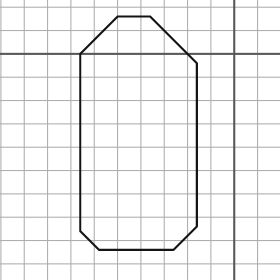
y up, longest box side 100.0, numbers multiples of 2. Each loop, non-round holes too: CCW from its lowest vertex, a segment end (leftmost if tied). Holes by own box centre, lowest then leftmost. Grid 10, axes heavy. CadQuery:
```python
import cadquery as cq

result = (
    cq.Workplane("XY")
    .moveTo(-58.0, -84.0)
    .lineTo(-26.0, -84.0)
    .lineTo(-16.0, -74.0)
    .lineTo(-16.0, -4.0)
    .lineTo(-36.0, 16.0)
    .lineTo(-50.0, 16.0)
    .lineTo(-66.0, 0.0)
    .lineTo(-66.0, -76.0)
    .close()
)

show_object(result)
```